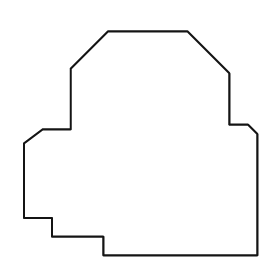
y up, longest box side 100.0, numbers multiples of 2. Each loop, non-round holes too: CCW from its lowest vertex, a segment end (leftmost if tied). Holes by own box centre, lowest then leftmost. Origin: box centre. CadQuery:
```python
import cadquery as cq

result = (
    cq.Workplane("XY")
    .moveTo(-16.0, -48.0)
    .lineTo(50.0, -48.0)
    .lineTo(50.0, 4.0)
    .lineTo(46.0, 8.0)
    .lineTo(38.0, 8.0)
    .lineTo(38.0, 30.0)
    .lineTo(20.0, 48.0)
    .lineTo(-14.0, 48.0)
    .lineTo(-30.0, 32.0)
    .lineTo(-30.0, 6.0)
    .lineTo(-42.0, 6.0)
    .lineTo(-50.0, 0.0)
    .lineTo(-50.0, -32.0)
    .lineTo(-38.0, -32.0)
    .lineTo(-38.0, -40.0)
    .lineTo(-16.0, -40.0)
    .close()
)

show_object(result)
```